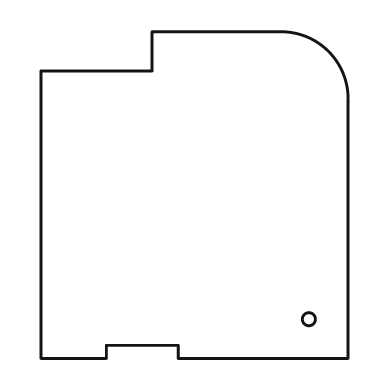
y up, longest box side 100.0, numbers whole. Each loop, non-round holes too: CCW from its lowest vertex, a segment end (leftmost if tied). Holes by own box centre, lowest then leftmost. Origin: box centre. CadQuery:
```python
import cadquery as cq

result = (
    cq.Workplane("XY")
    .moveTo(-47.0, -50.0)
    .lineTo(-27.0, -50.0)
    .lineTo(-27.0, -46.0)
    .lineTo(-5.0, -46.0)
    .lineTo(-5.0, -50.0)
    .lineTo(47.0, -50.0)
    .lineTo(47.0, 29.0)
    .threePointArc((41.0, 44.0), (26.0, 50.0))
    .lineTo(-13.0, 50.0)
    .lineTo(-13.0, 38.0)
    .lineTo(-47.0, 38.0)
    .close()
    .moveTo(35.0, -38.0)
    .circle(2.0)
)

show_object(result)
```